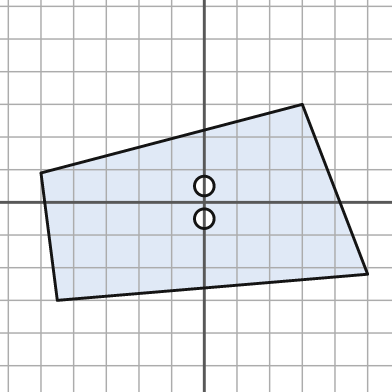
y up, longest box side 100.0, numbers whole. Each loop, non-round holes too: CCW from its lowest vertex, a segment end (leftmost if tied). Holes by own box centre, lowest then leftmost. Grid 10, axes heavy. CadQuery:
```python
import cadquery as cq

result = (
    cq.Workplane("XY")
    .moveTo(-45.0, -30.0)
    .lineTo(50.0, -22.0)
    .lineTo(30.0, 30.0)
    .lineTo(-50.0, 9.0)
    .close()
    .moveTo(0.0, -5.0)
    .circle(3.0)
    .moveTo(0.0, 5.0)
    .circle(3.0)
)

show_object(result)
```